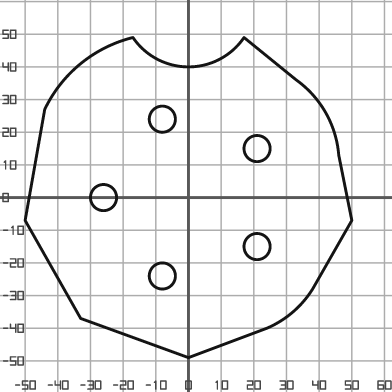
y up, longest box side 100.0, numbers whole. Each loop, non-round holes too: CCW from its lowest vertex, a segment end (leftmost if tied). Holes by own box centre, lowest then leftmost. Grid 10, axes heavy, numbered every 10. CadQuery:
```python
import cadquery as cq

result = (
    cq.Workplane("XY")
    .moveTo(0.0, -49.0)
    .lineTo(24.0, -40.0)
    .threePointArc((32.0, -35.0), (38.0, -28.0))
    .lineTo(50.0, -7.0)
    .lineTo(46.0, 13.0)
    .threePointArc((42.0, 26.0), (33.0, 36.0))
    .lineTo(17.0, 49.0)
    .threePointArc((0.0, 40.0), (-17.0, 49.0))
    .threePointArc((-33.0, 41.0), (-44.0, 27.0))
    .lineTo(-50.0, -7.0)
    .lineTo(-33.0, -37.0)
    .close()
    .moveTo(-8.0, -24.0)
    .circle(4.0)
    .moveTo(21.0, -15.0)
    .circle(4.0)
    .moveTo(-26.0, 0.0)
    .circle(4.0)
    .moveTo(21.0, 15.0)
    .circle(4.0)
    .moveTo(-8.0, 24.0)
    .circle(4.0)
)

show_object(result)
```